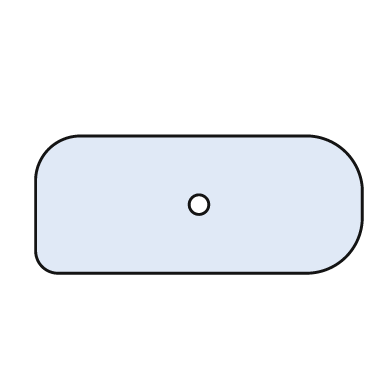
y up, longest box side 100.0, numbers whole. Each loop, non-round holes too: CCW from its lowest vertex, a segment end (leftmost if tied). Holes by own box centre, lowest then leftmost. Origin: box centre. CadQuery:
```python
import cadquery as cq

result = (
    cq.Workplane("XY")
    .moveTo(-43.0, -21.0)
    .lineTo(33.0, -21.0)
    .threePointArc((45.0, -16.0), (50.0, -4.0))
    .lineTo(50.0, 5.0)
    .threePointArc((45.0, 16.0), (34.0, 21.0))
    .lineTo(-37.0, 21.0)
    .threePointArc((-46.0, 17.0), (-50.0, 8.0))
    .lineTo(-50.0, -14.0)
    .threePointArc((-48.0, -19.0), (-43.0, -21.0))
    .close()
    .moveTo(0.0, 0.0)
    .circle(3.0)
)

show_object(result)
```